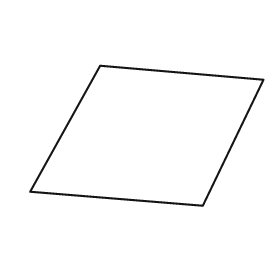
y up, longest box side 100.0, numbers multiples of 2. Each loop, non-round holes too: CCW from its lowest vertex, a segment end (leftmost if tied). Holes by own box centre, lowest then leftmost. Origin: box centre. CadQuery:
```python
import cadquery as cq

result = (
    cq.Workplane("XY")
    .moveTo(24.0, -30.0)
    .lineTo(50.0, 24.0)
    .lineTo(-20.0, 30.0)
    .lineTo(-50.0, -24.0)
    .close()
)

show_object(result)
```